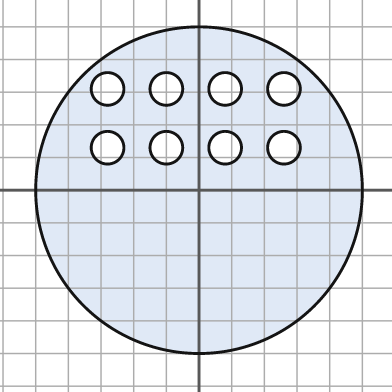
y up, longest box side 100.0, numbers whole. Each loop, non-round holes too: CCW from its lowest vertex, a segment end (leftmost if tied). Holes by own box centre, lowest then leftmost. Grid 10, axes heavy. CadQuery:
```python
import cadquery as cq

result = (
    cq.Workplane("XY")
    .moveTo(0.0, 0.0)
    .circle(50.0)
    .moveTo(-28.0, 13.0)
    .circle(5.0)
    .moveTo(-10.0, 13.0)
    .circle(5.0)
    .moveTo(8.0, 13.0)
    .circle(5.0)
    .moveTo(26.0, 13.0)
    .circle(5.0)
    .moveTo(-28.0, 31.0)
    .circle(5.0)
    .moveTo(-10.0, 31.0)
    .circle(5.0)
    .moveTo(8.0, 31.0)
    .circle(5.0)
    .moveTo(26.0, 31.0)
    .circle(5.0)
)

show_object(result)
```